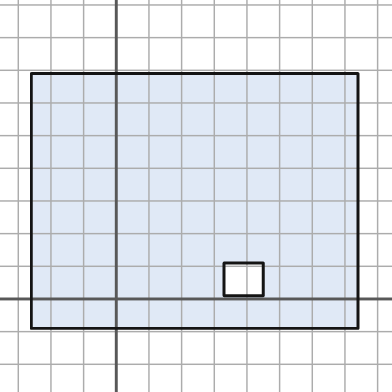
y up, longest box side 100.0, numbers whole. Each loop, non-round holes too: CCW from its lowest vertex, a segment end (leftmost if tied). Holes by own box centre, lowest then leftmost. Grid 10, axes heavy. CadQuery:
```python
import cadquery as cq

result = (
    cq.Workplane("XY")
    .moveTo(-26.0, -9.0)
    .lineTo(74.0, -9.0)
    .lineTo(74.0, 69.0)
    .lineTo(-26.0, 69.0)
    .close()
    .moveTo(33.0, 1.0)
    .lineTo(45.0, 1.0)
    .lineTo(45.0, 11.0)
    .lineTo(33.0, 11.0)
    .close()
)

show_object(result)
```